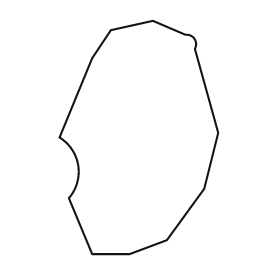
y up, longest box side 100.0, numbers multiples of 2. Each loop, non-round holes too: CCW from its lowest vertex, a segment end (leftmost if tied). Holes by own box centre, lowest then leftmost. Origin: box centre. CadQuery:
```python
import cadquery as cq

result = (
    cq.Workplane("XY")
    .moveTo(-20.0, -50.0)
    .lineTo(-4.0, -50.0)
    .lineTo(12.0, -44.0)
    .lineTo(28.0, -22.0)
    .lineTo(34.0, 2.0)
    .lineTo(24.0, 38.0)
    .threePointArc((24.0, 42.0), (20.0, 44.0))
    .lineTo(6.0, 50.0)
    .lineTo(-12.0, 46.0)
    .lineTo(-20.0, 34.0)
    .lineTo(-34.0, 0.0)
    .threePointArc((-26.0, -12.0), (-30.0, -26.0))
    .close()
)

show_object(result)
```